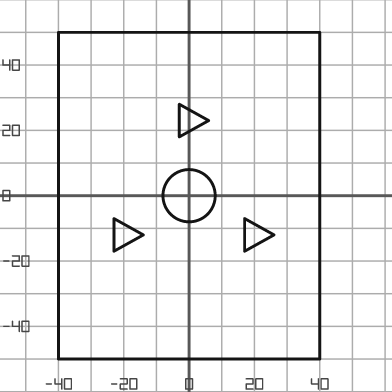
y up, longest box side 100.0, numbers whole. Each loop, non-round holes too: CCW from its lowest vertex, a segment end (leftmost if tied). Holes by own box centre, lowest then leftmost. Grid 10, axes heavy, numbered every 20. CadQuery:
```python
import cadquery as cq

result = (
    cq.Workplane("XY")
    .moveTo(-40.0, -50.0)
    .lineTo(40.0, -50.0)
    .lineTo(40.0, 50.0)
    .lineTo(-40.0, 50.0)
    .close()
    .moveTo(-23.0, -17.0)
    .lineTo(-14.0, -12.0)
    .lineTo(-23.0, -7.0)
    .close()
    .moveTo(17.0, -17.0)
    .lineTo(26.0, -12.0)
    .lineTo(17.0, -7.0)
    .close()
    .moveTo(0.0, 0.0)
    .circle(8.0)
    .moveTo(-3.0, 18.0)
    .lineTo(6.0, 23.0)
    .lineTo(-3.0, 28.0)
    .close()
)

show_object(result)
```